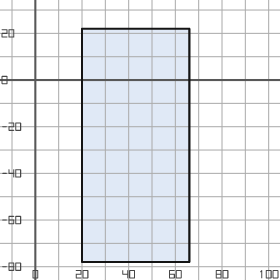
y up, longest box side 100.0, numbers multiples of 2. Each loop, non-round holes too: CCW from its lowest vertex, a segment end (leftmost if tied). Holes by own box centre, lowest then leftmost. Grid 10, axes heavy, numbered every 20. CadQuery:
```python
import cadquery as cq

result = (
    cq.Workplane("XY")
    .moveTo(20.0, -78.0)
    .lineTo(66.0, -78.0)
    .lineTo(66.0, 22.0)
    .lineTo(20.0, 22.0)
    .close()
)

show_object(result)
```